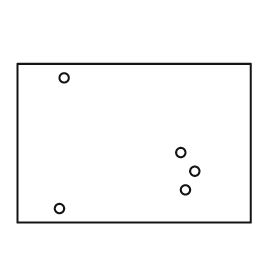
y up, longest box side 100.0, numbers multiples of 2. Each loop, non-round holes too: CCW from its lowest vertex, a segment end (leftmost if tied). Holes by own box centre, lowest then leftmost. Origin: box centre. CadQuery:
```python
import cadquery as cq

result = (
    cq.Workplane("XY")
    .moveTo(-50.0, -34.0)
    .lineTo(50.0, -34.0)
    .lineTo(50.0, 34.0)
    .lineTo(-50.0, 34.0)
    .close()
    .moveTo(-32.0, -28.0)
    .circle(2.0)
    .moveTo(22.0, -20.0)
    .circle(2.0)
    .moveTo(26.0, -12.0)
    .circle(2.0)
    .moveTo(20.0, -4.0)
    .circle(2.0)
    .moveTo(-30.0, 28.0)
    .circle(2.0)
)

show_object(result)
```